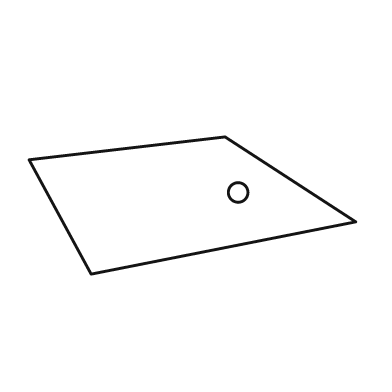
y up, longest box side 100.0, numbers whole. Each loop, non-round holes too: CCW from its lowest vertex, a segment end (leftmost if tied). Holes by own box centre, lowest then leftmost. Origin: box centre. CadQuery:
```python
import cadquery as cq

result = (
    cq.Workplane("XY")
    .moveTo(-31.0, -21.0)
    .lineTo(50.0, -5.0)
    .lineTo(10.0, 21.0)
    .lineTo(-50.0, 14.0)
    .close()
    .moveTo(14.0, 4.0)
    .circle(3.0)
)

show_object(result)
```